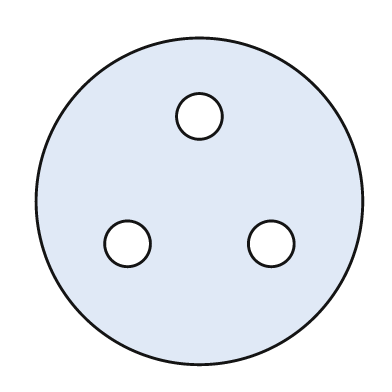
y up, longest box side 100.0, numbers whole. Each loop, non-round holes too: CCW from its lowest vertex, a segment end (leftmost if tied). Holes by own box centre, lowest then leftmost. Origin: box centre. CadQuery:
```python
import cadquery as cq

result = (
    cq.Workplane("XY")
    .moveTo(0.0, 0.0)
    .circle(50.0)
    .moveTo(-22.0, -13.0)
    .circle(7.0)
    .moveTo(22.0, -13.0)
    .circle(7.0)
    .moveTo(0.0, 26.0)
    .circle(7.0)
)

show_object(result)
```